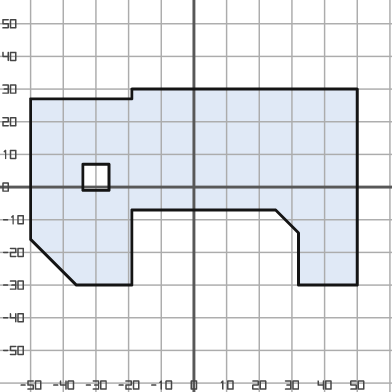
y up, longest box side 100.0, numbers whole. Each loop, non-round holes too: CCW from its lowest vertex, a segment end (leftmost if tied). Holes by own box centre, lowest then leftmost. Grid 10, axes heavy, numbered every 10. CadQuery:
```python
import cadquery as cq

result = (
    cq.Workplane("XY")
    .moveTo(-36.0, -30.0)
    .lineTo(-19.0, -30.0)
    .lineTo(-19.0, -7.0)
    .lineTo(25.0, -7.0)
    .lineTo(32.0, -14.0)
    .lineTo(32.0, -30.0)
    .lineTo(50.0, -30.0)
    .lineTo(50.0, 30.0)
    .lineTo(-19.0, 30.0)
    .lineTo(-19.0, 27.0)
    .lineTo(-50.0, 27.0)
    .lineTo(-50.0, -16.0)
    .close()
    .moveTo(-34.0, -1.0)
    .lineTo(-26.0, -1.0)
    .lineTo(-26.0, 7.0)
    .lineTo(-34.0, 7.0)
    .close()
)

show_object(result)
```